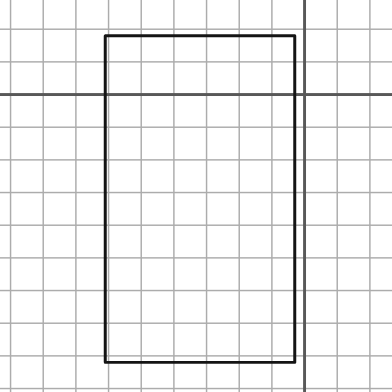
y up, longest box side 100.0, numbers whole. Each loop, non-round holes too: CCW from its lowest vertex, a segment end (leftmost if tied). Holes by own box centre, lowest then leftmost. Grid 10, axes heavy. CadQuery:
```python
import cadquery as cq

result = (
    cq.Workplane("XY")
    .moveTo(-61.0, -82.0)
    .lineTo(-3.0, -82.0)
    .lineTo(-3.0, 18.0)
    .lineTo(-61.0, 18.0)
    .close()
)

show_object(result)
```